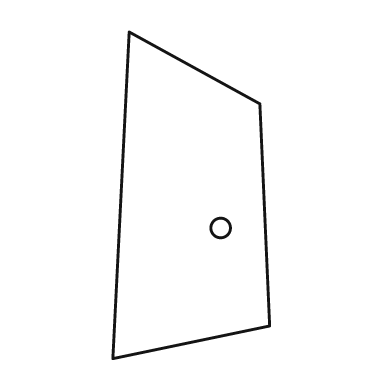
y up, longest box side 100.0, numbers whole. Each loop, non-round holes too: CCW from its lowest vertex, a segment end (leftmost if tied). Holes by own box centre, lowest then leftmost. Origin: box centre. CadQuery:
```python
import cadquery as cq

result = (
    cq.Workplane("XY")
    .moveTo(-24.0, -50.0)
    .lineTo(24.0, -40.0)
    .lineTo(21.0, 28.0)
    .lineTo(-19.0, 50.0)
    .close()
    .moveTo(9.0, -10.0)
    .circle(3.0)
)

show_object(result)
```